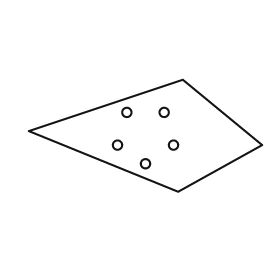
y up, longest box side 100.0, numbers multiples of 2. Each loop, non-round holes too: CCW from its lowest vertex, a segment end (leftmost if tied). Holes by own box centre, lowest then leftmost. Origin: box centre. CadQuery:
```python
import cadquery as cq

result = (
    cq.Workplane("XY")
    .moveTo(14.0, -24.0)
    .lineTo(50.0, -4.0)
    .lineTo(16.0, 24.0)
    .lineTo(-50.0, 2.0)
    .close()
    .moveTo(0.0, -12.0)
    .circle(2.0)
    .moveTo(-12.0, -4.0)
    .circle(2.0)
    .moveTo(12.0, -4.0)
    .circle(2.0)
    .moveTo(-8.0, 10.0)
    .circle(2.0)
    .moveTo(8.0, 10.0)
    .circle(2.0)
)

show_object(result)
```